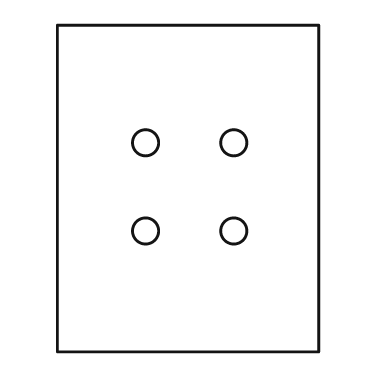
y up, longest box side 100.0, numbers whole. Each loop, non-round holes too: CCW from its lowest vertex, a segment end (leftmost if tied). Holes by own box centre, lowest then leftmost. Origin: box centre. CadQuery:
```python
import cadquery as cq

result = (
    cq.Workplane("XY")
    .moveTo(-40.0, -50.0)
    .lineTo(40.0, -50.0)
    .lineTo(40.0, 50.0)
    .lineTo(-40.0, 50.0)
    .close()
    .moveTo(-13.0, -13.0)
    .circle(4.0)
    .moveTo(14.0, -13.0)
    .circle(4.0)
    .moveTo(-13.0, 14.0)
    .circle(4.0)
    .moveTo(14.0, 14.0)
    .circle(4.0)
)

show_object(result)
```